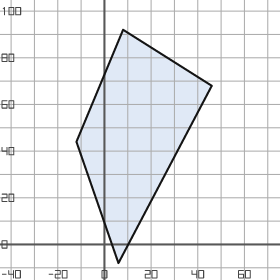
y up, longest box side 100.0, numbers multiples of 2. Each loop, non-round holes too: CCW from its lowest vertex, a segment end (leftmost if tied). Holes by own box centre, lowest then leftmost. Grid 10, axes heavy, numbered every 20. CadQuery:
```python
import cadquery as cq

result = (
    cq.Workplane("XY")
    .moveTo(6.0, -8.0)
    .lineTo(46.0, 68.0)
    .lineTo(8.0, 92.0)
    .lineTo(-12.0, 44.0)
    .close()
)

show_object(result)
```